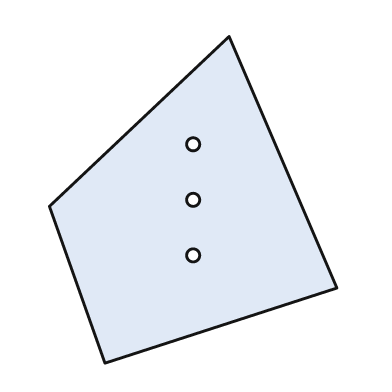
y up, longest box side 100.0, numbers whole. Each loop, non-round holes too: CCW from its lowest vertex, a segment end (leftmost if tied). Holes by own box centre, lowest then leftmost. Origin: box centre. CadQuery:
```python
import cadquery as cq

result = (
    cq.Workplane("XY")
    .moveTo(-27.0, -50.0)
    .lineTo(44.0, -27.0)
    .lineTo(11.0, 50.0)
    .lineTo(-44.0, -2.0)
    .close()
    .moveTo(0.0, -17.0)
    .circle(2.0)
    .moveTo(0.0, 0.0)
    .circle(2.0)
    .moveTo(0.0, 17.0)
    .circle(2.0)
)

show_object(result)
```